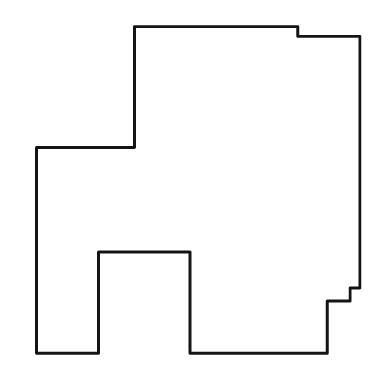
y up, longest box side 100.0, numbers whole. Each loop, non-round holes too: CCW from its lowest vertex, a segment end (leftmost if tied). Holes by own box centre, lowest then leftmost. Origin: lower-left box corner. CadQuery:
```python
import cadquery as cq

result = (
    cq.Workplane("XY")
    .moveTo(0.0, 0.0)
    .lineTo(19.0, 0.0)
    .lineTo(19.0, 31.0)
    .lineTo(47.0, 31.0)
    .lineTo(47.0, 0.0)
    .lineTo(89.0, 0.0)
    .lineTo(89.0, 16.0)
    .lineTo(96.0, 16.0)
    .lineTo(96.0, 20.0)
    .lineTo(99.0, 20.0)
    .lineTo(99.0, 97.0)
    .lineTo(80.0, 97.0)
    .lineTo(80.0, 100.0)
    .lineTo(30.0, 100.0)
    .lineTo(30.0, 63.0)
    .lineTo(0.0, 63.0)
    .close()
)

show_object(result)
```